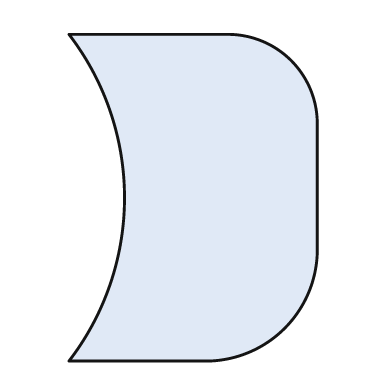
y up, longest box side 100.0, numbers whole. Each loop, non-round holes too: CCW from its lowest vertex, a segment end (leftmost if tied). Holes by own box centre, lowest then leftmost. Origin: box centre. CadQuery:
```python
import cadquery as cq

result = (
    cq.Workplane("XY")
    .moveTo(-38.0, -50.0)
    .lineTo(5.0, -50.0)
    .threePointArc((28.0, -40.0), (38.0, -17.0))
    .lineTo(38.0, 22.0)
    .threePointArc((30.0, 42.0), (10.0, 50.0))
    .lineTo(-38.0, 50.0)
    .threePointArc((-21.0, 0.0), (-38.0, -50.0))
    .close()
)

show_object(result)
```